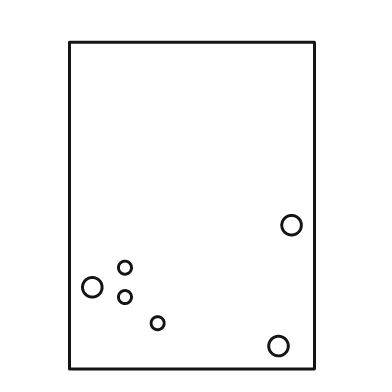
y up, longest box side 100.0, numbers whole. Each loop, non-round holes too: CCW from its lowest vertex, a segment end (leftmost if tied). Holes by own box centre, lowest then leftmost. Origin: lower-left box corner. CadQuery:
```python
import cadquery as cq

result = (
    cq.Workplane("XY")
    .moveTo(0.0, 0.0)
    .lineTo(75.0, 0.0)
    .lineTo(75.0, 100.0)
    .lineTo(0.0, 100.0)
    .close()
    .moveTo(64.0, 7.0)
    .circle(3.0)
    .moveTo(27.0, 14.0)
    .circle(2.0)
    .moveTo(17.0, 22.0)
    .circle(2.0)
    .moveTo(7.0, 25.0)
    .circle(3.0)
    .moveTo(17.0, 31.0)
    .circle(2.0)
    .moveTo(68.0, 44.0)
    .circle(3.0)
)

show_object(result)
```